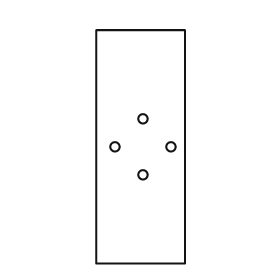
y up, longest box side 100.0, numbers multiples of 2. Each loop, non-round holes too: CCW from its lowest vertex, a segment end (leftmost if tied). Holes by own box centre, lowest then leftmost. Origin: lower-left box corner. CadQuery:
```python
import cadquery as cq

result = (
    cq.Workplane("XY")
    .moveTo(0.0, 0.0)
    .lineTo(38.0, 0.0)
    .lineTo(38.0, 100.0)
    .lineTo(0.0, 100.0)
    .close()
    .moveTo(20.0, 38.0)
    .circle(2.0)
    .moveTo(8.0, 50.0)
    .circle(2.0)
    .moveTo(32.0, 50.0)
    .circle(2.0)
    .moveTo(20.0, 62.0)
    .circle(2.0)
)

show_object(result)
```